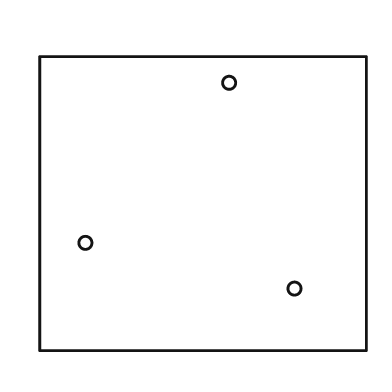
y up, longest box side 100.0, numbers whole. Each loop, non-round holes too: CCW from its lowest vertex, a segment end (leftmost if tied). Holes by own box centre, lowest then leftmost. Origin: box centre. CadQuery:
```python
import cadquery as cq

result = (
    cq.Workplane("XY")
    .moveTo(-50.0, -45.0)
    .lineTo(50.0, -45.0)
    .lineTo(50.0, 45.0)
    .lineTo(-50.0, 45.0)
    .close()
    .moveTo(28.0, -26.0)
    .circle(2.0)
    .moveTo(-36.0, -12.0)
    .circle(2.0)
    .moveTo(8.0, 37.0)
    .circle(2.0)
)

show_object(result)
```